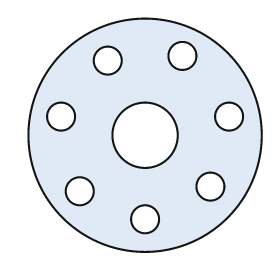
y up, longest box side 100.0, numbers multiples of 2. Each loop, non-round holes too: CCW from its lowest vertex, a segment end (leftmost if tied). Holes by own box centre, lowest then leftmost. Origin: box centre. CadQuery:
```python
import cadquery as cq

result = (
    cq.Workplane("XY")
    .moveTo(0.0, 0.0)
    .circle(50.0)
    .moveTo(0.0, -36.0)
    .circle(6.0)
    .moveTo(-28.0, -24.0)
    .circle(6.0)
    .moveTo(28.0, -22.0)
    .circle(6.0)
    .moveTo(0.0, 0.0)
    .circle(14.0)
    .moveTo(-36.0, 8.0)
    .circle(6.0)
    .moveTo(36.0, 8.0)
    .circle(6.0)
    .moveTo(-16.0, 32.0)
    .circle(6.0)
    .moveTo(16.0, 34.0)
    .circle(6.0)
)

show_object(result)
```